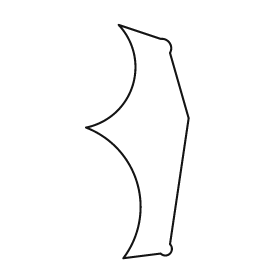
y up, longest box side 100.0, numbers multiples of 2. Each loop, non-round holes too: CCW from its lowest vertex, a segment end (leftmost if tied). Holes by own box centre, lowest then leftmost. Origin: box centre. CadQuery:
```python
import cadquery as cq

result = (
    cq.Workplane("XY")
    .moveTo(-6.0, -50.0)
    .lineTo(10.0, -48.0)
    .threePointArc((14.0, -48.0), (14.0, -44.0))
    .lineTo(22.0, 10.0)
    .lineTo(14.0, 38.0)
    .threePointArc((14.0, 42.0), (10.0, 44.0))
    .lineTo(-8.0, 50.0)
    .threePointArc((-2.0, 24.0), (-22.0, 6.0))
    .threePointArc((0.0, -18.0), (-6.0, -50.0))
    .close()
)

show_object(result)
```